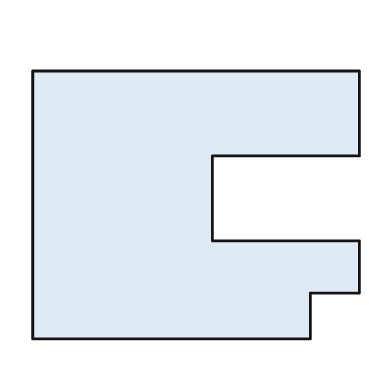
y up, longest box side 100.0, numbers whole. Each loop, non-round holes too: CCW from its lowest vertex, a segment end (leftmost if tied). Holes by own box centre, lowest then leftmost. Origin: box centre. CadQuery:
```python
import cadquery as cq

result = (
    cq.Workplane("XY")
    .moveTo(-50.0, -41.0)
    .lineTo(35.0, -41.0)
    .lineTo(35.0, -27.0)
    .lineTo(50.0, -27.0)
    .lineTo(50.0, -11.0)
    .lineTo(5.0, -11.0)
    .lineTo(5.0, 15.0)
    .lineTo(50.0, 15.0)
    .lineTo(50.0, 41.0)
    .lineTo(-50.0, 41.0)
    .close()
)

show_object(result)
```